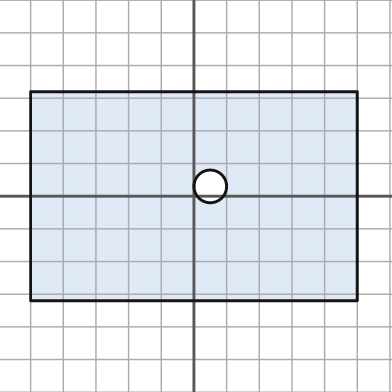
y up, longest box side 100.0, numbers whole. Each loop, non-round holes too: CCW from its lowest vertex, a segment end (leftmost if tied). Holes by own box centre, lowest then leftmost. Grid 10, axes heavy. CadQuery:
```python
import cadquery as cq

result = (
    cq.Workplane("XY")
    .moveTo(-50.0, -32.0)
    .lineTo(50.0, -32.0)
    .lineTo(50.0, 32.0)
    .lineTo(-50.0, 32.0)
    .close()
    .moveTo(5.0, 3.0)
    .circle(5.0)
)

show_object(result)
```